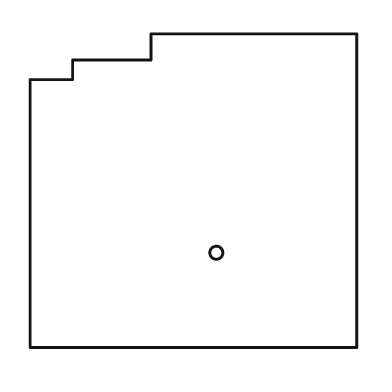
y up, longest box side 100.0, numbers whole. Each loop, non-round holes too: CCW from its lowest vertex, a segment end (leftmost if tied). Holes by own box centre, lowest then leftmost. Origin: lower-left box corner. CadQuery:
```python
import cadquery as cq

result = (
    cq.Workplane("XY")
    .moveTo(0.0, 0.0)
    .lineTo(100.0, 0.0)
    .lineTo(100.0, 96.0)
    .lineTo(37.0, 96.0)
    .lineTo(37.0, 88.0)
    .lineTo(13.0, 88.0)
    .lineTo(13.0, 82.0)
    .lineTo(0.0, 82.0)
    .close()
    .moveTo(57.0, 29.0)
    .circle(2.0)
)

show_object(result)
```